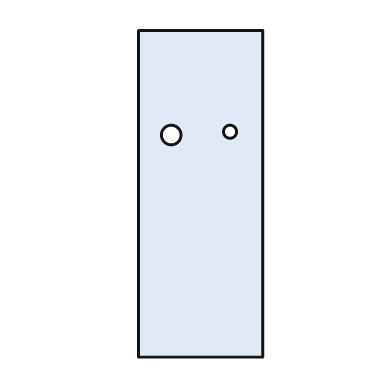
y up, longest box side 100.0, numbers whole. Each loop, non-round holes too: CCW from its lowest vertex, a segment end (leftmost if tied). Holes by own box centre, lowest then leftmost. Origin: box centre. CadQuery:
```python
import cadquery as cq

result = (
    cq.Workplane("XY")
    .moveTo(-19.0, -50.0)
    .lineTo(19.0, -50.0)
    .lineTo(19.0, 50.0)
    .lineTo(-19.0, 50.0)
    .close()
    .moveTo(-9.0, 18.0)
    .circle(3.0)
    .moveTo(9.0, 19.0)
    .circle(2.0)
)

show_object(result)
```